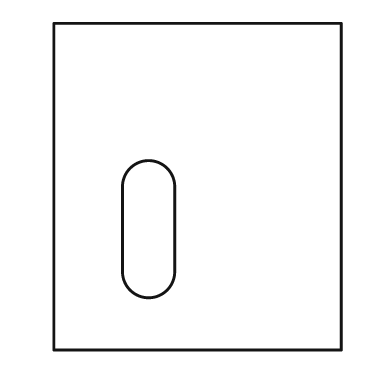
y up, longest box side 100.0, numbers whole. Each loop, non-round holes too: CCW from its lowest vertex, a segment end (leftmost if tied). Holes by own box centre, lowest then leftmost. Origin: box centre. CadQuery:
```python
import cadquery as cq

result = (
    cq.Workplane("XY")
    .moveTo(-44.0, -50.0)
    .lineTo(44.0, -50.0)
    .lineTo(44.0, 50.0)
    .lineTo(-44.0, 50.0)
    .close()
    .moveTo(-23.0, -26.0)
    .threePointArc((-15.0, -34.0), (-7.0, -26.0))
    .lineTo(-7.0, 0.0)
    .threePointArc((-15.0, 8.0), (-23.0, 0.0))
    .close()
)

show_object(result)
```